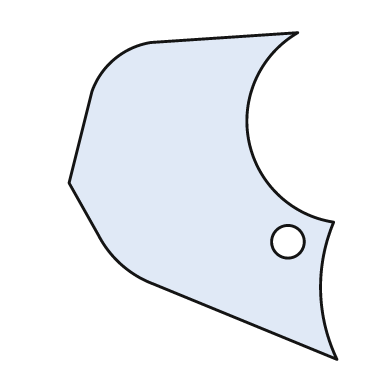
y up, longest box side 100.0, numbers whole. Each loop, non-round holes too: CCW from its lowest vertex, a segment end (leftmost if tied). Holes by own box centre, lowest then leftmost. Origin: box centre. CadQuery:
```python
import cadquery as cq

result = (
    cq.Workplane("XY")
    .moveTo(41.0, -50.0)
    .threePointArc((36.0, -29.0), (40.0, -8.0))
    .threePointArc((14.0, 17.0), (29.0, 50.0))
    .lineTo(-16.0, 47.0)
    .threePointArc((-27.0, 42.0), (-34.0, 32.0))
    .lineTo(-41.0, 4.0)
    .lineTo(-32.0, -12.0)
    .threePointArc((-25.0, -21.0), (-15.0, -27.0))
    .close()
    .moveTo(26.0, -14.0)
    .circle(5.0)
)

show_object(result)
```